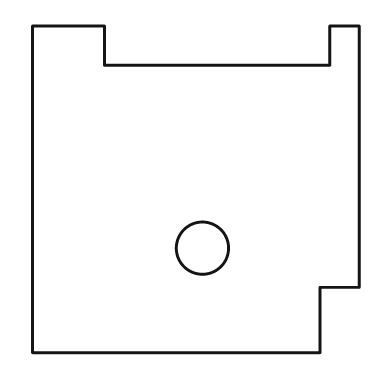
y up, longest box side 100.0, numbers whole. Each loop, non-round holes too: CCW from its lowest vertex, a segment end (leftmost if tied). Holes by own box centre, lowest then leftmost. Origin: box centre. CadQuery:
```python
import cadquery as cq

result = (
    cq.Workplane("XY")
    .moveTo(-50.0, -50.0)
    .lineTo(38.0, -50.0)
    .lineTo(38.0, -30.0)
    .lineTo(50.0, -30.0)
    .lineTo(50.0, 50.0)
    .lineTo(41.0, 50.0)
    .lineTo(41.0, 38.0)
    .lineTo(-28.0, 38.0)
    .lineTo(-28.0, 50.0)
    .lineTo(-50.0, 50.0)
    .close()
    .moveTo(2.0, -18.0)
    .circle(8.0)
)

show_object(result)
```